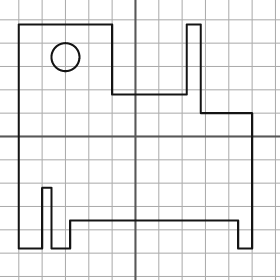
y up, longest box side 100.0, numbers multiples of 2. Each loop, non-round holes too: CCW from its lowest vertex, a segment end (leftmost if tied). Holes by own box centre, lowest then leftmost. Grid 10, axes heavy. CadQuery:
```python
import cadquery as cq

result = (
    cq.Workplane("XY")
    .moveTo(-50.0, -48.0)
    .lineTo(-40.0, -48.0)
    .lineTo(-40.0, -22.0)
    .lineTo(-36.0, -22.0)
    .lineTo(-36.0, -48.0)
    .lineTo(-28.0, -48.0)
    .lineTo(-28.0, -36.0)
    .lineTo(44.0, -36.0)
    .lineTo(44.0, -48.0)
    .lineTo(50.0, -48.0)
    .lineTo(50.0, 10.0)
    .lineTo(28.0, 10.0)
    .lineTo(28.0, 48.0)
    .lineTo(22.0, 48.0)
    .lineTo(22.0, 18.0)
    .lineTo(-10.0, 18.0)
    .lineTo(-10.0, 48.0)
    .lineTo(-50.0, 48.0)
    .close()
    .moveTo(-30.0, 34.0)
    .circle(6.0)
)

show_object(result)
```